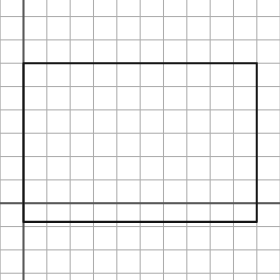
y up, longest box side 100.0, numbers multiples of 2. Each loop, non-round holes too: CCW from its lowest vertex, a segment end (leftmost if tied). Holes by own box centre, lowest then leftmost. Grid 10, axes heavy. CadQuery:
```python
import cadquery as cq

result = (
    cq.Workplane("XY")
    .moveTo(0.0, -8.0)
    .lineTo(100.0, -8.0)
    .lineTo(100.0, 60.0)
    .lineTo(0.0, 60.0)
    .close()
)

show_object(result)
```